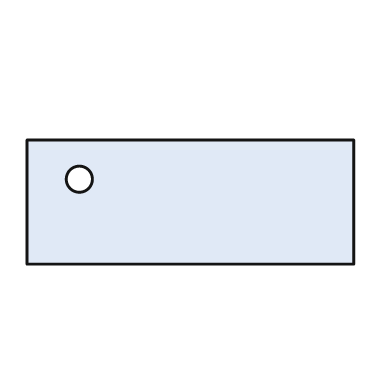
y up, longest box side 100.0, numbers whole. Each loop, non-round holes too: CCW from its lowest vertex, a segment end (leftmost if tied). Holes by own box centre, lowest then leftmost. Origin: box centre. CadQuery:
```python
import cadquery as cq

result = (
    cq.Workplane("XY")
    .moveTo(-50.0, -19.0)
    .lineTo(50.0, -19.0)
    .lineTo(50.0, 19.0)
    .lineTo(-50.0, 19.0)
    .close()
    .moveTo(-34.0, 7.0)
    .circle(4.0)
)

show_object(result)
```